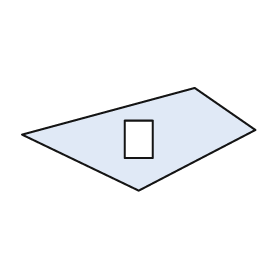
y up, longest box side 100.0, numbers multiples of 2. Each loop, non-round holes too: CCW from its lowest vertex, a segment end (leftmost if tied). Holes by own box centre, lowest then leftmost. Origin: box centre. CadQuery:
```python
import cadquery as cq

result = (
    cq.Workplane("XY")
    .moveTo(0.0, -22.0)
    .lineTo(50.0, 4.0)
    .lineTo(24.0, 22.0)
    .lineTo(-50.0, 2.0)
    .close()
    .moveTo(-6.0, -8.0)
    .lineTo(6.0, -8.0)
    .lineTo(6.0, 8.0)
    .lineTo(-6.0, 8.0)
    .close()
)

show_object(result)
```